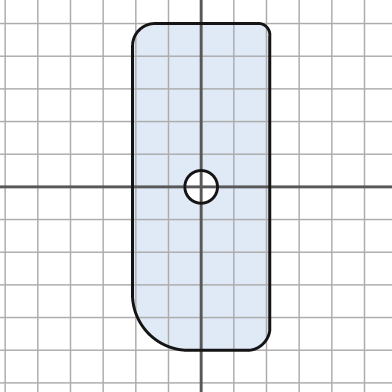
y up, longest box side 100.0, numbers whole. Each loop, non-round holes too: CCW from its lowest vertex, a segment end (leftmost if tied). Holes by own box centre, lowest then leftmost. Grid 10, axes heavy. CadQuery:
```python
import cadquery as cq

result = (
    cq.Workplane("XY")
    .moveTo(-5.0, -50.0)
    .lineTo(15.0, -50.0)
    .threePointArc((19.0, -48.0), (21.0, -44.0))
    .lineTo(21.0, 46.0)
    .threePointArc((20.0, 49.0), (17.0, 50.0))
    .lineTo(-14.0, 50.0)
    .threePointArc((-19.0, 48.0), (-21.0, 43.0))
    .lineTo(-21.0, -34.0)
    .threePointArc((-16.0, -45.0), (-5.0, -50.0))
    .close()
    .moveTo(0.0, 0.0)
    .circle(5.0)
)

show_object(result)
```